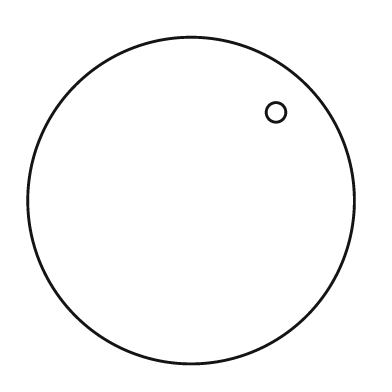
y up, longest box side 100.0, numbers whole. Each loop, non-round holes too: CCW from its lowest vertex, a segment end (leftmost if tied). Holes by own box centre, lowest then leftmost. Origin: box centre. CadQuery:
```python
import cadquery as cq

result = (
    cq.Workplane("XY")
    .moveTo(0.0, 0.0)
    .circle(50.0)
    .moveTo(26.0, 27.0)
    .circle(3.0)
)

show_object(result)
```